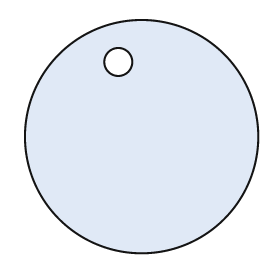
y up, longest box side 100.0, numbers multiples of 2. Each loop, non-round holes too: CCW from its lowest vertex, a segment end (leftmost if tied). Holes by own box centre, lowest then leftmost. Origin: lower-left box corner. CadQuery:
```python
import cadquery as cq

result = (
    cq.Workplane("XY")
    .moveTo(50.0, 50.0)
    .circle(50.0)
    .moveTo(40.0, 82.0)
    .circle(6.0)
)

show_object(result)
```